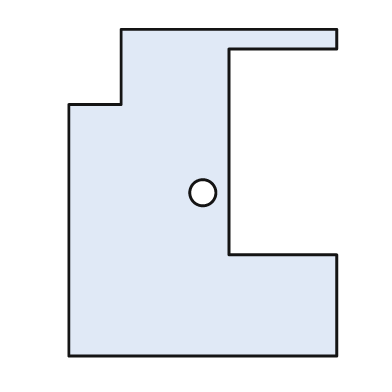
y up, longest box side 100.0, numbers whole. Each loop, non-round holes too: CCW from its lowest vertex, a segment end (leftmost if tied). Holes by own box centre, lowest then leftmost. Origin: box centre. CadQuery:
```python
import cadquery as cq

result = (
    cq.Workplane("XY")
    .moveTo(-41.0, -50.0)
    .lineTo(41.0, -50.0)
    .lineTo(41.0, -19.0)
    .lineTo(8.0, -19.0)
    .lineTo(8.0, 44.0)
    .lineTo(41.0, 44.0)
    .lineTo(41.0, 50.0)
    .lineTo(-25.0, 50.0)
    .lineTo(-25.0, 27.0)
    .lineTo(-41.0, 27.0)
    .close()
    .moveTo(0.0, 0.0)
    .circle(4.0)
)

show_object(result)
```